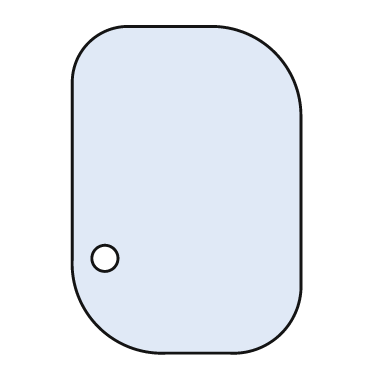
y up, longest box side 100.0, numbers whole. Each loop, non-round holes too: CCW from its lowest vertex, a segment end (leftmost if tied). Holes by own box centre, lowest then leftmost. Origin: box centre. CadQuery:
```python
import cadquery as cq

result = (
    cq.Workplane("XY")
    .moveTo(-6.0, -50.0)
    .lineTo(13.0, -50.0)
    .threePointArc((29.0, -44.0), (35.0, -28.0))
    .lineTo(35.0, 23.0)
    .threePointArc((27.0, 42.0), (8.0, 50.0))
    .lineTo(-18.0, 50.0)
    .threePointArc((-30.0, 45.0), (-35.0, 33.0))
    .lineTo(-35.0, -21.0)
    .threePointArc((-27.0, -42.0), (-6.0, -50.0))
    .close()
    .moveTo(-25.0, -21.0)
    .circle(4.0)
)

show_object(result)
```